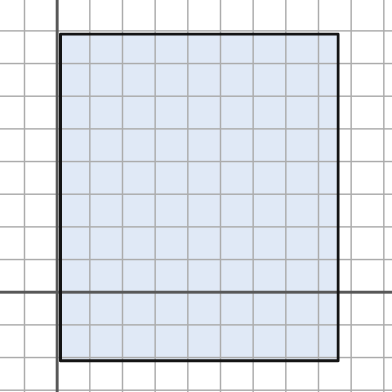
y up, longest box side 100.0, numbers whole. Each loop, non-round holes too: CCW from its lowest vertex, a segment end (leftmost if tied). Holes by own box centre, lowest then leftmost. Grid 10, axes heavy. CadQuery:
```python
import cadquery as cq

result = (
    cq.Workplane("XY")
    .moveTo(1.0, -21.0)
    .lineTo(86.0, -21.0)
    .lineTo(86.0, 79.0)
    .lineTo(1.0, 79.0)
    .close()
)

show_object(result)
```